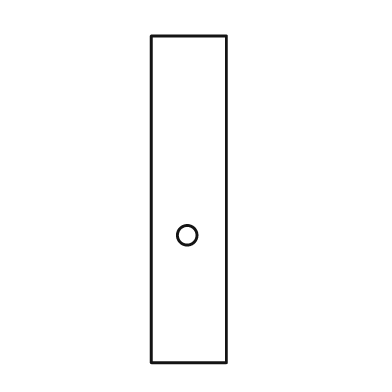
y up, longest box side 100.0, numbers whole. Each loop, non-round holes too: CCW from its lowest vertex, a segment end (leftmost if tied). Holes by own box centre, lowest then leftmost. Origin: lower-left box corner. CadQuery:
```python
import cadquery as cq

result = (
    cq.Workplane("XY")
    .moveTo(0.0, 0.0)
    .lineTo(23.0, 0.0)
    .lineTo(23.0, 100.0)
    .lineTo(0.0, 100.0)
    .close()
    .moveTo(11.0, 39.0)
    .circle(3.0)
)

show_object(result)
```